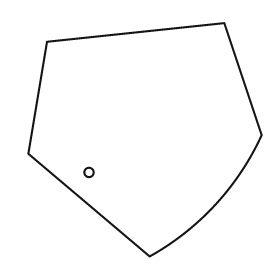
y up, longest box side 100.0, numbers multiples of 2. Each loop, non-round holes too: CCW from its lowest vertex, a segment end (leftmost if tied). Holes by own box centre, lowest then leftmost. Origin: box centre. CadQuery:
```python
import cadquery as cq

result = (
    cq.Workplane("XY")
    .moveTo(2.0, -50.0)
    .threePointArc((30.0, -28.0), (50.0, 2.0))
    .lineTo(34.0, 50.0)
    .lineTo(-42.0, 42.0)
    .lineTo(-50.0, -6.0)
    .close()
    .moveTo(-24.0, -14.0)
    .circle(2.0)
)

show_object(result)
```